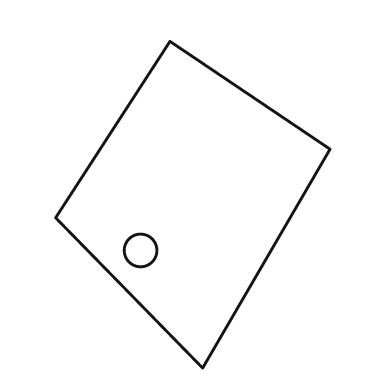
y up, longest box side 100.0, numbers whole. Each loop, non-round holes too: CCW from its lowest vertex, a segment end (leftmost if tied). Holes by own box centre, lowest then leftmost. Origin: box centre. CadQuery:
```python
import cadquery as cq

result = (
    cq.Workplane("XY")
    .moveTo(3.0, -50.0)
    .lineTo(42.0, 17.0)
    .lineTo(-7.0, 50.0)
    .lineTo(-42.0, -4.0)
    .close()
    .moveTo(-16.0, -14.0)
    .circle(5.0)
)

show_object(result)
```